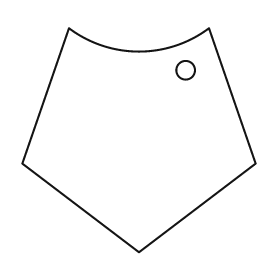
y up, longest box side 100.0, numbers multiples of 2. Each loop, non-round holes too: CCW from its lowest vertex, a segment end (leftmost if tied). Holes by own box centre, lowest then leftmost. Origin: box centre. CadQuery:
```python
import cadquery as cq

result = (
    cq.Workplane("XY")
    .moveTo(0.0, -48.0)
    .lineTo(50.0, -10.0)
    .lineTo(30.0, 48.0)
    .threePointArc((0.0, 38.0), (-30.0, 48.0))
    .lineTo(-50.0, -10.0)
    .close()
    .moveTo(20.0, 30.0)
    .circle(4.0)
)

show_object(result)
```